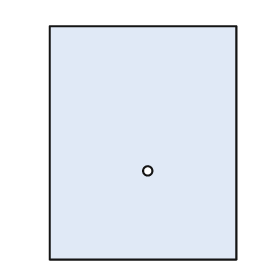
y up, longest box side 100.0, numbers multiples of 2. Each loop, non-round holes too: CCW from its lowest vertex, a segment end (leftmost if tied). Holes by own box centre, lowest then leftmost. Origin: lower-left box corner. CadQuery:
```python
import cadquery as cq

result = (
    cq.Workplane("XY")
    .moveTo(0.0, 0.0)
    .lineTo(80.0, 0.0)
    .lineTo(80.0, 100.0)
    .lineTo(0.0, 100.0)
    .close()
    .moveTo(42.0, 38.0)
    .circle(2.0)
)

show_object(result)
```